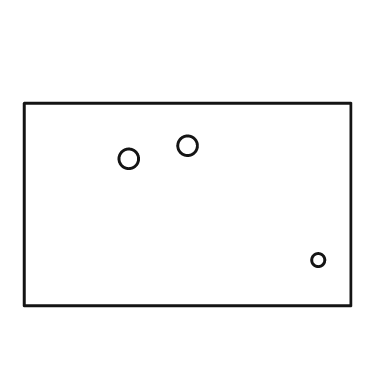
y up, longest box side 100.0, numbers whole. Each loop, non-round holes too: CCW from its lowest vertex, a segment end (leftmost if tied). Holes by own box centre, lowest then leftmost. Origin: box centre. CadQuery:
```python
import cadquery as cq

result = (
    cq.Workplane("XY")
    .moveTo(-50.0, -31.0)
    .lineTo(50.0, -31.0)
    .lineTo(50.0, 31.0)
    .lineTo(-50.0, 31.0)
    .close()
    .moveTo(40.0, -17.0)
    .circle(2.0)
    .moveTo(-18.0, 14.0)
    .circle(3.0)
    .moveTo(0.0, 18.0)
    .circle(3.0)
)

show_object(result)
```